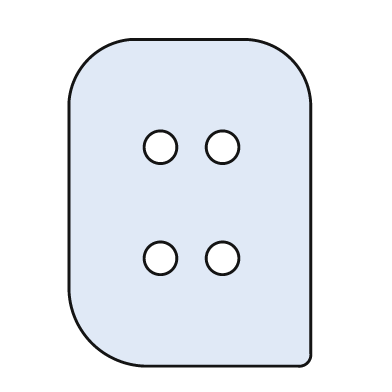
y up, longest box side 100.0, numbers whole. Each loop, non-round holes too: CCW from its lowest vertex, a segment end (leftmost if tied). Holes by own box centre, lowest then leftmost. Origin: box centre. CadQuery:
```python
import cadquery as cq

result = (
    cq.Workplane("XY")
    .moveTo(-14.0, -50.0)
    .lineTo(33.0, -50.0)
    .threePointArc((36.0, -49.0), (37.0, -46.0))
    .lineTo(37.0, 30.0)
    .threePointArc((31.0, 44.0), (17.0, 50.0))
    .lineTo(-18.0, 50.0)
    .threePointArc((-31.0, 44.0), (-37.0, 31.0))
    .lineTo(-37.0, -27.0)
    .threePointArc((-30.0, -43.0), (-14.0, -50.0))
    .close()
    .moveTo(-9.0, -17.0)
    .circle(5.0)
    .moveTo(10.0, -17.0)
    .circle(5.0)
    .moveTo(-9.0, 17.0)
    .circle(5.0)
    .moveTo(10.0, 17.0)
    .circle(5.0)
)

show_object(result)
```